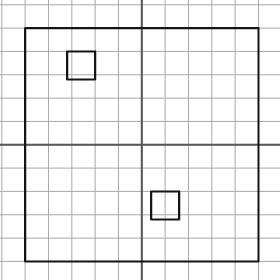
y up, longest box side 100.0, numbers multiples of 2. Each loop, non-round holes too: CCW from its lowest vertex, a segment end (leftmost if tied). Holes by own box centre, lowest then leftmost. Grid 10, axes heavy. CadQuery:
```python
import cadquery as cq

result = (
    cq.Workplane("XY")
    .moveTo(-50.0, -50.0)
    .lineTo(50.0, -50.0)
    .lineTo(50.0, 50.0)
    .lineTo(-50.0, 50.0)
    .close()
    .moveTo(4.0, -32.0)
    .lineTo(16.0, -32.0)
    .lineTo(16.0, -20.0)
    .lineTo(4.0, -20.0)
    .close()
    .moveTo(-32.0, 28.0)
    .lineTo(-20.0, 28.0)
    .lineTo(-20.0, 40.0)
    .lineTo(-32.0, 40.0)
    .close()
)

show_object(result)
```